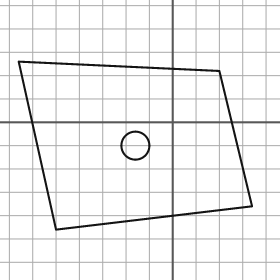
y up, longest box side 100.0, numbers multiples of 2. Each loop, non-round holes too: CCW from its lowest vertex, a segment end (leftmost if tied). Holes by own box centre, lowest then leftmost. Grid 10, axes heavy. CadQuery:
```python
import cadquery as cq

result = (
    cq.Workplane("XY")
    .moveTo(-50.0, -46.0)
    .lineTo(34.0, -36.0)
    .lineTo(20.0, 22.0)
    .lineTo(-66.0, 26.0)
    .close()
    .moveTo(-16.0, -10.0)
    .circle(6.0)
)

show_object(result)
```